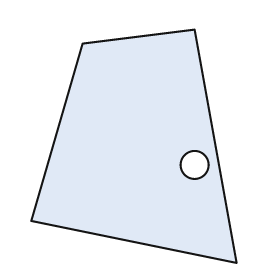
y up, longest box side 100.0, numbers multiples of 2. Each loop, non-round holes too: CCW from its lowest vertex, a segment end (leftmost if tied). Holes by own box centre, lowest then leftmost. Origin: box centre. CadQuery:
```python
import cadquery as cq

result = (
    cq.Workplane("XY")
    .moveTo(44.0, -50.0)
    .lineTo(26.0, 50.0)
    .lineTo(-22.0, 44.0)
    .lineTo(-44.0, -32.0)
    .close()
    .moveTo(26.0, -8.0)
    .circle(6.0)
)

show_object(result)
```